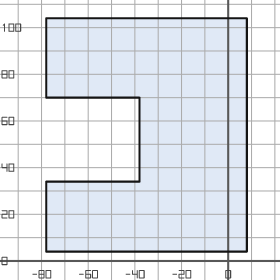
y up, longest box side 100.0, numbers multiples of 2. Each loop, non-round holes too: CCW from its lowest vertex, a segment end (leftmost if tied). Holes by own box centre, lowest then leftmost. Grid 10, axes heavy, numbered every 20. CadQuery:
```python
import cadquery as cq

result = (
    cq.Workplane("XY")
    .moveTo(-78.0, 4.0)
    .lineTo(8.0, 4.0)
    .lineTo(8.0, 104.0)
    .lineTo(-78.0, 104.0)
    .lineTo(-78.0, 70.0)
    .lineTo(-38.0, 70.0)
    .lineTo(-38.0, 34.0)
    .lineTo(-78.0, 34.0)
    .close()
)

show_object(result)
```